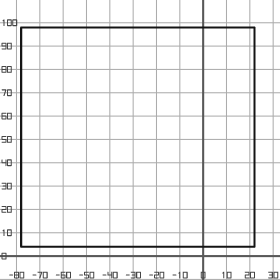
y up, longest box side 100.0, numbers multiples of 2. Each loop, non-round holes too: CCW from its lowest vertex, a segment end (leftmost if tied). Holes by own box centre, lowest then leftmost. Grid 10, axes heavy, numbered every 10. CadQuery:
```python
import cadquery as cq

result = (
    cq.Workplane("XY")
    .moveTo(-78.0, 4.0)
    .lineTo(22.0, 4.0)
    .lineTo(22.0, 98.0)
    .lineTo(-78.0, 98.0)
    .close()
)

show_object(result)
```